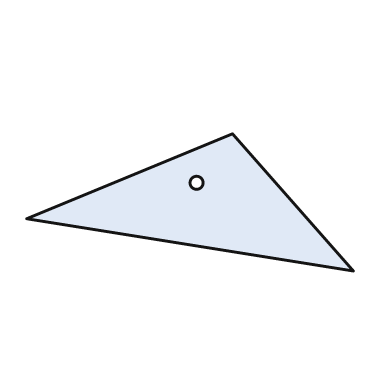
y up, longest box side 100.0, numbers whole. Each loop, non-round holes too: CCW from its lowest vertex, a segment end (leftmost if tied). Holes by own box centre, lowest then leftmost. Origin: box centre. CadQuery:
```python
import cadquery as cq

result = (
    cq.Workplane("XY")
    .moveTo(50.0, -21.0)
    .lineTo(13.0, 21.0)
    .lineTo(-50.0, -5.0)
    .close()
    .moveTo(2.0, 6.0)
    .circle(2.0)
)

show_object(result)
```